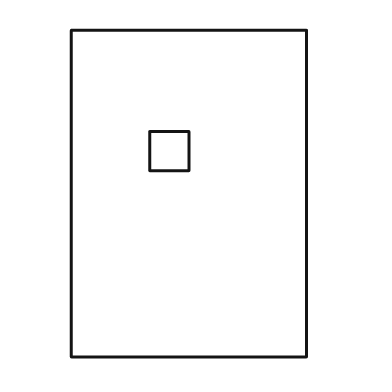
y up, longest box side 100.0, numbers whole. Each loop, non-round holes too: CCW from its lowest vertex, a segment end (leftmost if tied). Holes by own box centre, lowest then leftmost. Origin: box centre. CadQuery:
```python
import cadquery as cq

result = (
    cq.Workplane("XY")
    .moveTo(-36.0, -50.0)
    .lineTo(36.0, -50.0)
    .lineTo(36.0, 50.0)
    .lineTo(-36.0, 50.0)
    .close()
    .moveTo(-12.0, 7.0)
    .lineTo(0.0, 7.0)
    .lineTo(0.0, 19.0)
    .lineTo(-12.0, 19.0)
    .close()
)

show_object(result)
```